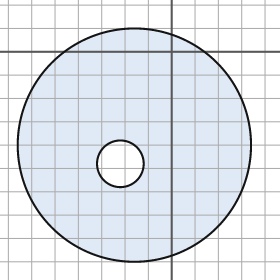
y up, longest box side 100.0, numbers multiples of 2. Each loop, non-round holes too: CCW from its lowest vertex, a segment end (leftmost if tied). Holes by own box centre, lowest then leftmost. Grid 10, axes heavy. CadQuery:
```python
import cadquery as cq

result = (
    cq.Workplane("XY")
    .moveTo(-16.0, -40.0)
    .circle(50.0)
    .moveTo(-22.0, -48.0)
    .circle(10.0)
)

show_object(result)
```